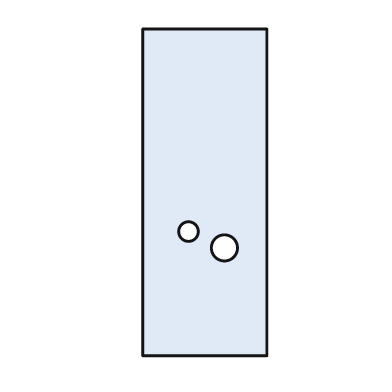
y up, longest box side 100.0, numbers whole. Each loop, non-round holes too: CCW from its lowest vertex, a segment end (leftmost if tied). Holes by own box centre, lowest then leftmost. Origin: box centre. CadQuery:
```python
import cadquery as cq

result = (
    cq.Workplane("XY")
    .moveTo(-19.0, -50.0)
    .lineTo(19.0, -50.0)
    .lineTo(19.0, 50.0)
    .lineTo(-19.0, 50.0)
    .close()
    .moveTo(6.0, -17.0)
    .circle(4.0)
    .moveTo(-5.0, -12.0)
    .circle(3.0)
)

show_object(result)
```